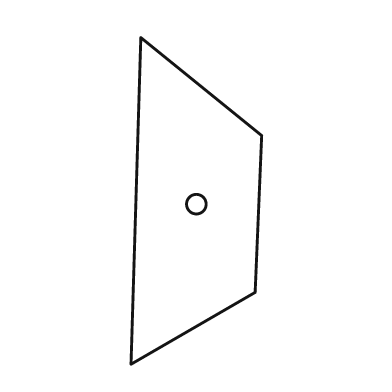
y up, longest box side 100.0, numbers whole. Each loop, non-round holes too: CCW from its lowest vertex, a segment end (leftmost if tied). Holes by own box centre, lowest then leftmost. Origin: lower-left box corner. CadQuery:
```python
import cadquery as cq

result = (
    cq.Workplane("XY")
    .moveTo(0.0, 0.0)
    .lineTo(38.0, 22.0)
    .lineTo(40.0, 70.0)
    .lineTo(3.0, 100.0)
    .close()
    .moveTo(20.0, 49.0)
    .circle(3.0)
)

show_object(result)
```